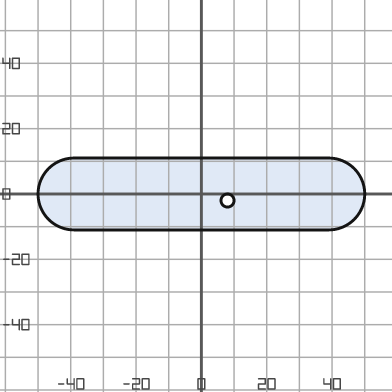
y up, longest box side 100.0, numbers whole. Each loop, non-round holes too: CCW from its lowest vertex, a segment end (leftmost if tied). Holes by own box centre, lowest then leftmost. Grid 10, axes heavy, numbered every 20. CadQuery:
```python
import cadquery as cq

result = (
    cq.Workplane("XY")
    .moveTo(-39.0, -11.0)
    .lineTo(39.0, -11.0)
    .threePointArc((50.0, 0.0), (39.0, 11.0))
    .lineTo(-39.0, 11.0)
    .threePointArc((-50.0, 0.0), (-39.0, -11.0))
    .close()
    .moveTo(8.0, -2.0)
    .circle(2.0)
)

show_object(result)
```